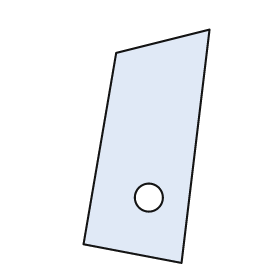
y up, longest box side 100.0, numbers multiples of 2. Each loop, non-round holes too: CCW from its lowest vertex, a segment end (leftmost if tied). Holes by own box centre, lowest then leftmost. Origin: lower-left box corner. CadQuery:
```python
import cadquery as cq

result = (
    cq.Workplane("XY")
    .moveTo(42.0, 0.0)
    .lineTo(54.0, 100.0)
    .lineTo(14.0, 90.0)
    .lineTo(0.0, 8.0)
    .close()
    .moveTo(28.0, 28.0)
    .circle(6.0)
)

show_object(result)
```